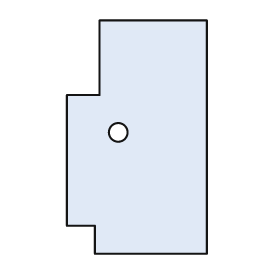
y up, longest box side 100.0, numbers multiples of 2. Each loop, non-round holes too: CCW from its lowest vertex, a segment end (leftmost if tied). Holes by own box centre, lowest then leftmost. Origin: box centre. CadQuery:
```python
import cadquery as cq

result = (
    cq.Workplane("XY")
    .moveTo(-18.0, -50.0)
    .lineTo(30.0, -50.0)
    .lineTo(30.0, 50.0)
    .lineTo(-16.0, 50.0)
    .lineTo(-16.0, 18.0)
    .lineTo(-30.0, 18.0)
    .lineTo(-30.0, -38.0)
    .lineTo(-18.0, -38.0)
    .close()
    .moveTo(-8.0, 2.0)
    .circle(4.0)
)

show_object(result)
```